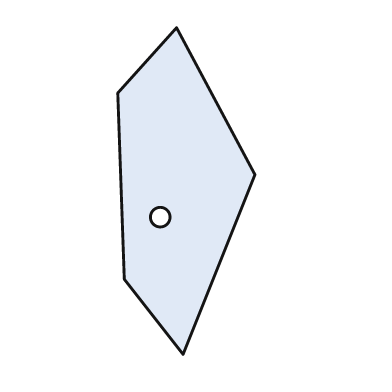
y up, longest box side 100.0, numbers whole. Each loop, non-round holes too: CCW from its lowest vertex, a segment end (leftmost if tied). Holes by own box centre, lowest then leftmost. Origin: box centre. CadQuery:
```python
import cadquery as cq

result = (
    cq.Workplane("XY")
    .moveTo(-1.0, -50.0)
    .lineTo(21.0, 5.0)
    .lineTo(-3.0, 50.0)
    .lineTo(-21.0, 30.0)
    .lineTo(-19.0, -27.0)
    .close()
    .moveTo(-8.0, -8.0)
    .circle(3.0)
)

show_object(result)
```